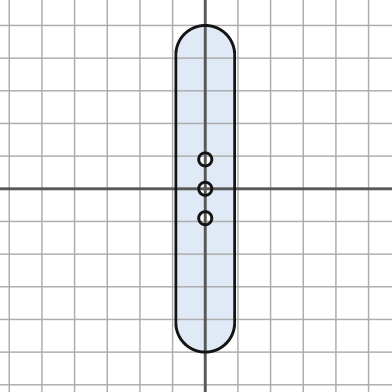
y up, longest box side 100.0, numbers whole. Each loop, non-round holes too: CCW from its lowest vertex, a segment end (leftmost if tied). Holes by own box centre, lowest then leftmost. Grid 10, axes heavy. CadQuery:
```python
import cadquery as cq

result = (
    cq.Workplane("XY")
    .moveTo(-9.0, -41.0)
    .threePointArc((0.0, -50.0), (9.0, -41.0))
    .lineTo(9.0, 41.0)
    .threePointArc((0.0, 50.0), (-9.0, 41.0))
    .close()
    .moveTo(0.0, -9.0)
    .circle(2.0)
    .moveTo(0.0, 0.0)
    .circle(2.0)
    .moveTo(0.0, 9.0)
    .circle(2.0)
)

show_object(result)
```